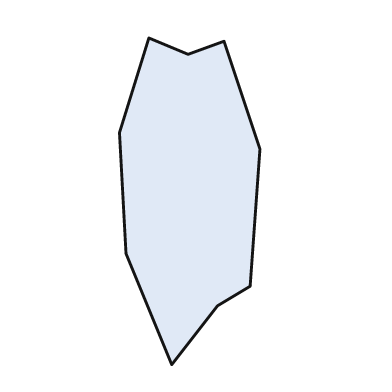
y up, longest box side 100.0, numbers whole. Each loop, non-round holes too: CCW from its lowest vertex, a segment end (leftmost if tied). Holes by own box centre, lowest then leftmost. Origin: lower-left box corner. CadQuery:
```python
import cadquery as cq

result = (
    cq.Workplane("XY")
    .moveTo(16.0, 0.0)
    .lineTo(30.0, 18.0)
    .lineTo(40.0, 24.0)
    .lineTo(43.0, 66.0)
    .lineTo(32.0, 99.0)
    .lineTo(21.0, 95.0)
    .lineTo(9.0, 100.0)
    .lineTo(0.0, 71.0)
    .lineTo(2.0, 34.0)
    .close()
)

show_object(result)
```